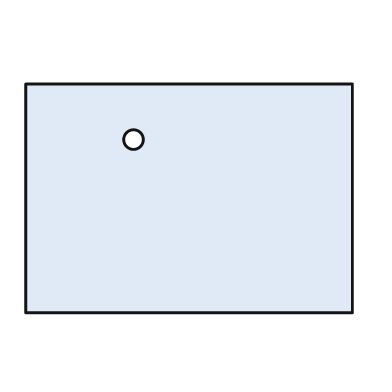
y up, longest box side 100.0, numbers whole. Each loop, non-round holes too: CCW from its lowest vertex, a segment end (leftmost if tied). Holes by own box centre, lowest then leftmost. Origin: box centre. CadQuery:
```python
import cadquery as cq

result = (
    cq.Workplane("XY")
    .moveTo(-50.0, -35.0)
    .lineTo(50.0, -35.0)
    .lineTo(50.0, 35.0)
    .lineTo(-50.0, 35.0)
    .close()
    .moveTo(-17.0, 18.0)
    .circle(3.0)
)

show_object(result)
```